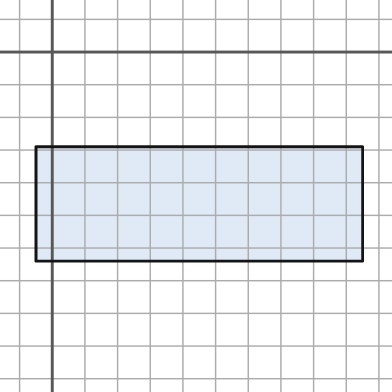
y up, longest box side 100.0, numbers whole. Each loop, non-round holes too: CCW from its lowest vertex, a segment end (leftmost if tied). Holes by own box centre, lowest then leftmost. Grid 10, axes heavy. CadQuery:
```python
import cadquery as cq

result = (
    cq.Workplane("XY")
    .moveTo(-5.0, -64.0)
    .lineTo(95.0, -64.0)
    .lineTo(95.0, -29.0)
    .lineTo(-5.0, -29.0)
    .close()
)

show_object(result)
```